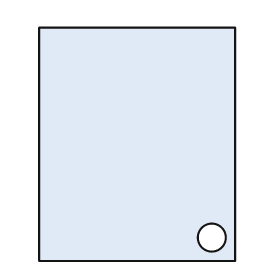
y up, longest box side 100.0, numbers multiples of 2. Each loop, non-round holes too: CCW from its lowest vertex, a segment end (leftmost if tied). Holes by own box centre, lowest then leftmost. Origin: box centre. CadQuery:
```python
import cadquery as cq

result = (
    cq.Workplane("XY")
    .moveTo(-42.0, -50.0)
    .lineTo(42.0, -50.0)
    .lineTo(42.0, 50.0)
    .lineTo(-42.0, 50.0)
    .close()
    .moveTo(32.0, -40.0)
    .circle(6.0)
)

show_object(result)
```